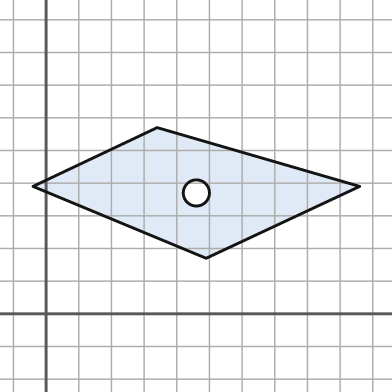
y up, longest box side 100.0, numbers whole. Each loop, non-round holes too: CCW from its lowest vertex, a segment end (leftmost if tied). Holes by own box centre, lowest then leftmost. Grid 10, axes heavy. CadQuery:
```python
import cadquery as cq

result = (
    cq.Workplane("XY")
    .moveTo(49.0, 17.0)
    .lineTo(96.0, 39.0)
    .lineTo(34.0, 57.0)
    .lineTo(-4.0, 39.0)
    .close()
    .moveTo(46.0, 37.0)
    .circle(4.0)
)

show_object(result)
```